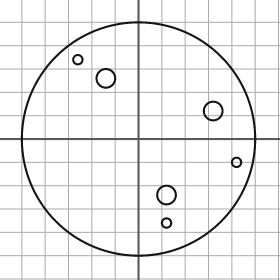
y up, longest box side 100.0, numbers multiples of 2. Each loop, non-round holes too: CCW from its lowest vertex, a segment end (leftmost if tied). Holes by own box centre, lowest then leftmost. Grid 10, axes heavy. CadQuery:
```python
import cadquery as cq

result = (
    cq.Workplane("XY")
    .moveTo(0.0, 0.0)
    .circle(50.0)
    .moveTo(12.0, -36.0)
    .circle(2.0)
    .moveTo(12.0, -24.0)
    .circle(4.0)
    .moveTo(42.0, -10.0)
    .circle(2.0)
    .moveTo(32.0, 12.0)
    .circle(4.0)
    .moveTo(-14.0, 26.0)
    .circle(4.0)
    .moveTo(-26.0, 34.0)
    .circle(2.0)
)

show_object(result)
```